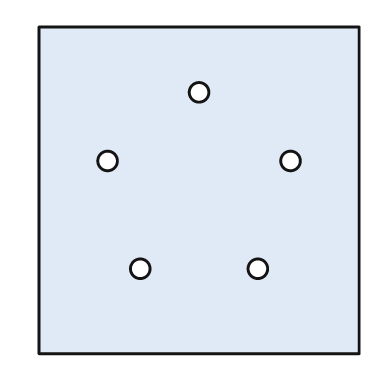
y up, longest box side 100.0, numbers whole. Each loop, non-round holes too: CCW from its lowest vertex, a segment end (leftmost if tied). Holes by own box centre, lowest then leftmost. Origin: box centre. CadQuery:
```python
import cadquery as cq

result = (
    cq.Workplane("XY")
    .moveTo(-49.0, -50.0)
    .lineTo(49.0, -50.0)
    .lineTo(49.0, 50.0)
    .lineTo(-49.0, 50.0)
    .close()
    .moveTo(-18.0, -24.0)
    .circle(3.0)
    .moveTo(18.0, -24.0)
    .circle(3.0)
    .moveTo(-28.0, 9.0)
    .circle(3.0)
    .moveTo(28.0, 9.0)
    .circle(3.0)
    .moveTo(0.0, 30.0)
    .circle(3.0)
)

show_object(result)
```